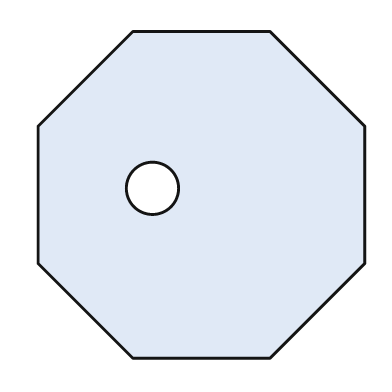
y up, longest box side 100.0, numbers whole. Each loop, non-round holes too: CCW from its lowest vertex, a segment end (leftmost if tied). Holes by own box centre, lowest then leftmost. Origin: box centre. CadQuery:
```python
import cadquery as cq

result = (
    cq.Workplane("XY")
    .moveTo(-21.0, -50.0)
    .lineTo(21.0, -50.0)
    .lineTo(50.0, -21.0)
    .lineTo(50.0, 21.0)
    .lineTo(21.0, 50.0)
    .lineTo(-21.0, 50.0)
    .lineTo(-50.0, 21.0)
    .lineTo(-50.0, -21.0)
    .close()
    .moveTo(-15.0, 2.0)
    .circle(8.0)
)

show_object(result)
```